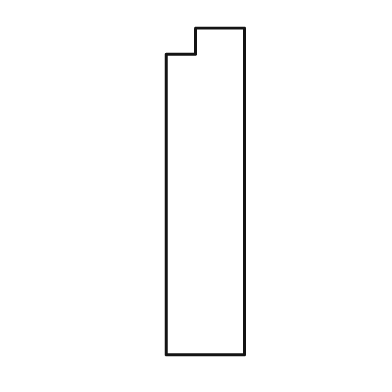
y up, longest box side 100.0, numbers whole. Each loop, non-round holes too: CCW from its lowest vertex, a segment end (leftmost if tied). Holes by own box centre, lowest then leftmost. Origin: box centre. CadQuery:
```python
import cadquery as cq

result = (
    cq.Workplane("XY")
    .moveTo(-12.0, -50.0)
    .lineTo(12.0, -50.0)
    .lineTo(12.0, 50.0)
    .lineTo(-3.0, 50.0)
    .lineTo(-3.0, 42.0)
    .lineTo(-12.0, 42.0)
    .close()
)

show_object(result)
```